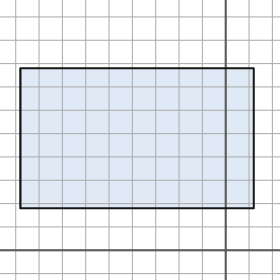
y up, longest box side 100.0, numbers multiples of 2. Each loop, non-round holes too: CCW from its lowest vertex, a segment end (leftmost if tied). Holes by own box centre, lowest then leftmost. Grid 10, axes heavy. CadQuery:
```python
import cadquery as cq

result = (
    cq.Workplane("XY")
    .moveTo(-88.0, 18.0)
    .lineTo(12.0, 18.0)
    .lineTo(12.0, 78.0)
    .lineTo(-88.0, 78.0)
    .close()
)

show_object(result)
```